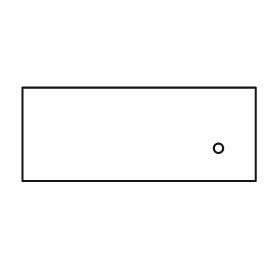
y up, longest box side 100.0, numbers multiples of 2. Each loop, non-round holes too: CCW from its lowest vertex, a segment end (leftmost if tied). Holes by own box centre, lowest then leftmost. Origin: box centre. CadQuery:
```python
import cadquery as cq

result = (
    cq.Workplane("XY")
    .moveTo(-50.0, -20.0)
    .lineTo(50.0, -20.0)
    .lineTo(50.0, 20.0)
    .lineTo(-50.0, 20.0)
    .close()
    .moveTo(34.0, -6.0)
    .circle(2.0)
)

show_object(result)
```